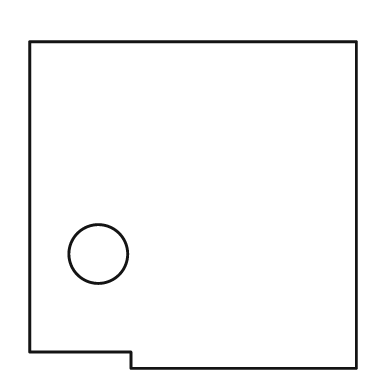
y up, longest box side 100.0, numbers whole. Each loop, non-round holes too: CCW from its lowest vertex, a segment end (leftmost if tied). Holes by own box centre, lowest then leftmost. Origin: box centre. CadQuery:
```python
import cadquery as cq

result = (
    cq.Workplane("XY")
    .moveTo(-19.0, -50.0)
    .lineTo(50.0, -50.0)
    .lineTo(50.0, 50.0)
    .lineTo(-50.0, 50.0)
    .lineTo(-50.0, -45.0)
    .lineTo(-19.0, -45.0)
    .close()
    .moveTo(-29.0, -15.0)
    .circle(9.0)
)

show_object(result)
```